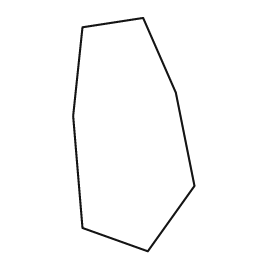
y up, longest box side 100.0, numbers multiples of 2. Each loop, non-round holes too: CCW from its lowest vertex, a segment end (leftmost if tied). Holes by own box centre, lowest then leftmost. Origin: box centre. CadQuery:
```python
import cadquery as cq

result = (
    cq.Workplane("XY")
    .moveTo(6.0, -50.0)
    .lineTo(26.0, -22.0)
    .lineTo(18.0, 18.0)
    .lineTo(4.0, 50.0)
    .lineTo(-22.0, 46.0)
    .lineTo(-26.0, 8.0)
    .lineTo(-22.0, -40.0)
    .close()
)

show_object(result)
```